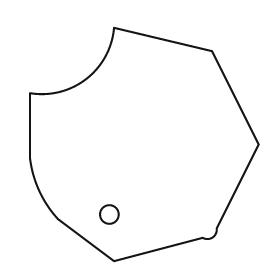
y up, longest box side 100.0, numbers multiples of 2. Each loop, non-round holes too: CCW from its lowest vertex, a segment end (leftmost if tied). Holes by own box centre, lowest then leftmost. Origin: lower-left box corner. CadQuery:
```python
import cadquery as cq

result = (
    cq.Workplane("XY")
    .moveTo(36.0, 0.0)
    .lineTo(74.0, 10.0)
    .threePointArc((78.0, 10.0), (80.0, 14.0))
    .lineTo(98.0, 50.0)
    .lineTo(78.0, 90.0)
    .lineTo(36.0, 100.0)
    .threePointArc((24.0, 78.0), (0.0, 72.0))
    .lineTo(0.0, 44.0)
    .threePointArc((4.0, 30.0), (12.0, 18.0))
    .close()
    .moveTo(34.0, 20.0)
    .circle(4.0)
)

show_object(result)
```